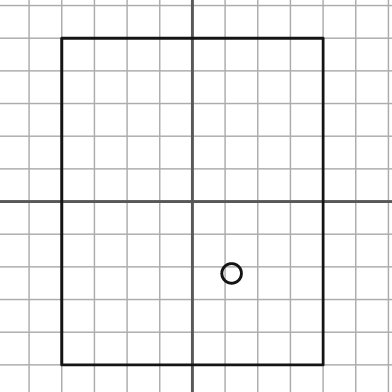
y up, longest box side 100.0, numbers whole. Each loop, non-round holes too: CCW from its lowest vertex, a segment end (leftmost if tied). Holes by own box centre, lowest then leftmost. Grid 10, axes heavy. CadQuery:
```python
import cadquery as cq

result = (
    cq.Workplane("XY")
    .moveTo(-40.0, -50.0)
    .lineTo(40.0, -50.0)
    .lineTo(40.0, 50.0)
    .lineTo(-40.0, 50.0)
    .close()
    .moveTo(12.0, -22.0)
    .circle(3.0)
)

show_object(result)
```